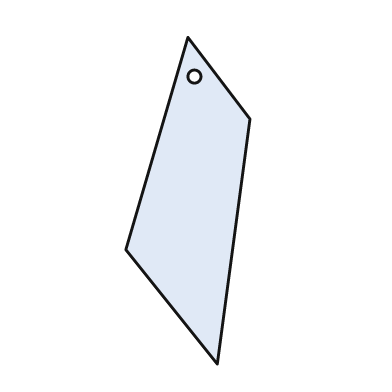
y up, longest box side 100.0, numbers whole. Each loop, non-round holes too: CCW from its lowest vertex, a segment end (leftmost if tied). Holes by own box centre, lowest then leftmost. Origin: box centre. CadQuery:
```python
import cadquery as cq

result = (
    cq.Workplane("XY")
    .moveTo(9.0, -50.0)
    .lineTo(19.0, 25.0)
    .lineTo(0.0, 50.0)
    .lineTo(-19.0, -15.0)
    .close()
    .moveTo(2.0, 38.0)
    .circle(2.0)
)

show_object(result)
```